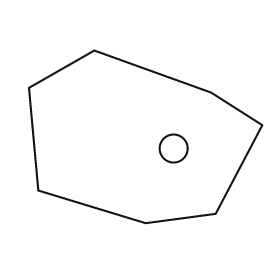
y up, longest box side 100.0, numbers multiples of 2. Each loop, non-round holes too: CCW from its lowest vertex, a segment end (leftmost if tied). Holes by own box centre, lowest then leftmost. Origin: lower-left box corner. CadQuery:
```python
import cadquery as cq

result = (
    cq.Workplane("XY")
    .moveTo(50.0, 0.0)
    .lineTo(80.0, 4.0)
    .lineTo(100.0, 42.0)
    .lineTo(78.0, 56.0)
    .lineTo(28.0, 74.0)
    .lineTo(0.0, 58.0)
    .lineTo(4.0, 14.0)
    .close()
    .moveTo(62.0, 32.0)
    .circle(6.0)
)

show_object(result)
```